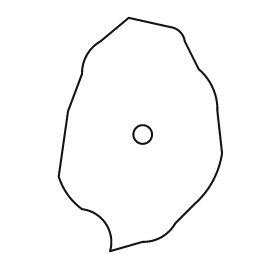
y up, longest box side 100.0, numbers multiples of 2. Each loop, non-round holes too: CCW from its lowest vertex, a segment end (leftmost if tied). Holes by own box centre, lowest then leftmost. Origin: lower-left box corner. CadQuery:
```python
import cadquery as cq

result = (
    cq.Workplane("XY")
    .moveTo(22.0, 0.0)
    .lineTo(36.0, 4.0)
    .threePointArc((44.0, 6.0), (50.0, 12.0))
    .lineTo(58.0, 20.0)
    .threePointArc((66.0, 30.0), (70.0, 42.0))
    .lineTo(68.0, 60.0)
    .threePointArc((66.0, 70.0), (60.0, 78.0))
    .lineTo(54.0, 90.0)
    .threePointArc((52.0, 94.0), (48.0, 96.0))
    .lineTo(30.0, 100.0)
    .lineTo(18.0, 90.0)
    .threePointArc((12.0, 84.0), (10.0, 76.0))
    .lineTo(4.0, 60.0)
    .lineTo(0.0, 32.0)
    .threePointArc((4.0, 24.0), (10.0, 18.0))
    .threePointArc((20.0, 12.0), (22.0, 0.0))
    .close()
    .moveTo(36.0, 50.0)
    .circle(4.0)
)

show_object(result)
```